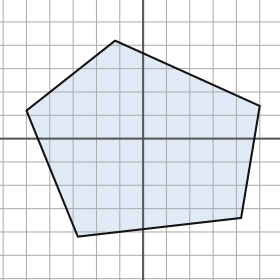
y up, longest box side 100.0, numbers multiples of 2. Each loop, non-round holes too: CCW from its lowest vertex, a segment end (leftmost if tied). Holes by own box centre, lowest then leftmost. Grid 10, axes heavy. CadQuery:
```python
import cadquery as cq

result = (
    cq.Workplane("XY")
    .moveTo(-28.0, -42.0)
    .lineTo(42.0, -34.0)
    .lineTo(50.0, 14.0)
    .lineTo(-12.0, 42.0)
    .lineTo(-50.0, 12.0)
    .close()
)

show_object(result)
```